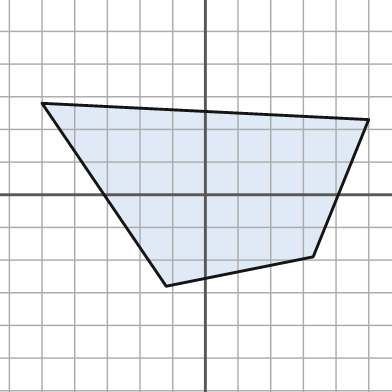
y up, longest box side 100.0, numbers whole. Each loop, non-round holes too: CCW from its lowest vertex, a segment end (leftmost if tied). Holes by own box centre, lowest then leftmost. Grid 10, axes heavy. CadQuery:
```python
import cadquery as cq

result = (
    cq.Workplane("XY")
    .moveTo(-12.0, -28.0)
    .lineTo(33.0, -19.0)
    .lineTo(50.0, 23.0)
    .lineTo(-50.0, 28.0)
    .close()
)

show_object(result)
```